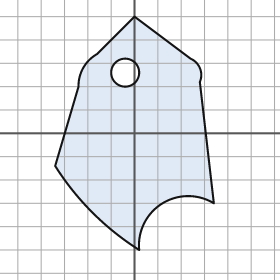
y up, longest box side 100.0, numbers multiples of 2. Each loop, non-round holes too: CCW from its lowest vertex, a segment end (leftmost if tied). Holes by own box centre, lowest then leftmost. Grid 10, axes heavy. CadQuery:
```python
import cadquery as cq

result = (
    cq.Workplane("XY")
    .moveTo(2.0, -50.0)
    .threePointArc((12.0, -30.0), (34.0, -30.0))
    .lineTo(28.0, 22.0)
    .threePointArc((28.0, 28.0), (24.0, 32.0))
    .lineTo(0.0, 50.0)
    .lineTo(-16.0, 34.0)
    .threePointArc((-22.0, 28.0), (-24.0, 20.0))
    .lineTo(-34.0, -14.0)
    .threePointArc((-18.0, -34.0), (2.0, -50.0))
    .close()
    .moveTo(-4.0, 26.0)
    .circle(6.0)
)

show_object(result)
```